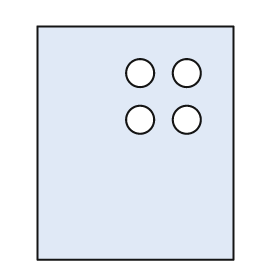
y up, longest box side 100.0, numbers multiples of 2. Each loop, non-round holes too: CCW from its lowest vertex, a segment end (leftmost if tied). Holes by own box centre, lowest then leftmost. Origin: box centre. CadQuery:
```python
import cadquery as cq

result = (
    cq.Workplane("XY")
    .moveTo(-42.0, -50.0)
    .lineTo(42.0, -50.0)
    .lineTo(42.0, 50.0)
    .lineTo(-42.0, 50.0)
    .close()
    .moveTo(2.0, 10.0)
    .circle(6.0)
    .moveTo(22.0, 10.0)
    .circle(6.0)
    .moveTo(2.0, 30.0)
    .circle(6.0)
    .moveTo(22.0, 30.0)
    .circle(6.0)
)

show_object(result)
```